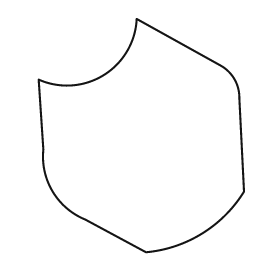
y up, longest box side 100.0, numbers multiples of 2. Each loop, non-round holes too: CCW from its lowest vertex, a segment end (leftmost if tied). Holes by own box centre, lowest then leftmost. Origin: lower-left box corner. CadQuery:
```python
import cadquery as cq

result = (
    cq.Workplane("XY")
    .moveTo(46.0, 0.0)
    .threePointArc((70.0, 8.0), (88.0, 26.0))
    .lineTo(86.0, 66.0)
    .threePointArc((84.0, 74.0), (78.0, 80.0))
    .lineTo(42.0, 100.0)
    .threePointArc((28.0, 76.0), (0.0, 74.0))
    .lineTo(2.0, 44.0)
    .threePointArc((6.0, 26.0), (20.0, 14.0))
    .close()
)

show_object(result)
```